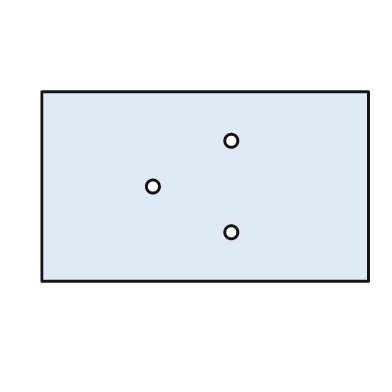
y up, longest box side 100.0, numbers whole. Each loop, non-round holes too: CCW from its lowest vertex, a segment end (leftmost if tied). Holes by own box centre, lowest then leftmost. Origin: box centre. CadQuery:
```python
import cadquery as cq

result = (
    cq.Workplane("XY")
    .moveTo(-50.0, -29.0)
    .lineTo(50.0, -29.0)
    .lineTo(50.0, 29.0)
    .lineTo(-50.0, 29.0)
    .close()
    .moveTo(8.0, -14.0)
    .circle(2.0)
    .moveTo(-16.0, 0.0)
    .circle(2.0)
    .moveTo(8.0, 14.0)
    .circle(2.0)
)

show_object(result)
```